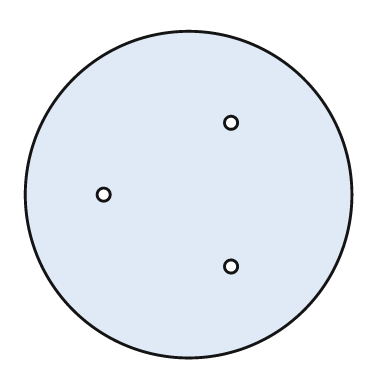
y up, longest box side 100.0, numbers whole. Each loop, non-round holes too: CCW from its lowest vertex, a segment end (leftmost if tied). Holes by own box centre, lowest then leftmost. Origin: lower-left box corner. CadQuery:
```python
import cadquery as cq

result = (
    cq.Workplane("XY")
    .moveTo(50.0, 50.0)
    .circle(50.0)
    .moveTo(63.0, 28.0)
    .circle(2.0)
    .moveTo(24.0, 50.0)
    .circle(2.0)
    .moveTo(63.0, 72.0)
    .circle(2.0)
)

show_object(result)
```